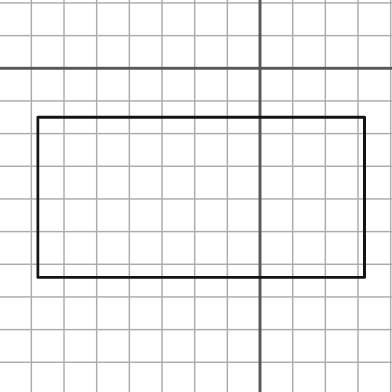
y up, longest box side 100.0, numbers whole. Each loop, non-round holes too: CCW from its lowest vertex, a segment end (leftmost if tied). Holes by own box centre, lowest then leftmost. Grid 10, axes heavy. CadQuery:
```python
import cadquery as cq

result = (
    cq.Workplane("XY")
    .moveTo(-68.0, -64.0)
    .lineTo(32.0, -64.0)
    .lineTo(32.0, -15.0)
    .lineTo(-68.0, -15.0)
    .close()
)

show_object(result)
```